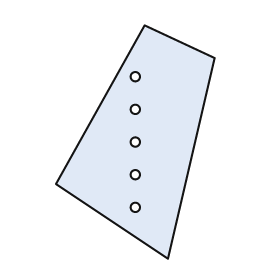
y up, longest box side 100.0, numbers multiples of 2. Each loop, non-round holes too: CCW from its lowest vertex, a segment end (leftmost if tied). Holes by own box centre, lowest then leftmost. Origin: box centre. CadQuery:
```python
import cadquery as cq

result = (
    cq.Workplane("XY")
    .moveTo(14.0, -50.0)
    .lineTo(34.0, 36.0)
    .lineTo(4.0, 50.0)
    .lineTo(-34.0, -18.0)
    .close()
    .moveTo(0.0, -28.0)
    .circle(2.0)
    .moveTo(0.0, -14.0)
    .circle(2.0)
    .moveTo(0.0, 0.0)
    .circle(2.0)
    .moveTo(0.0, 14.0)
    .circle(2.0)
    .moveTo(0.0, 28.0)
    .circle(2.0)
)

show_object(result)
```